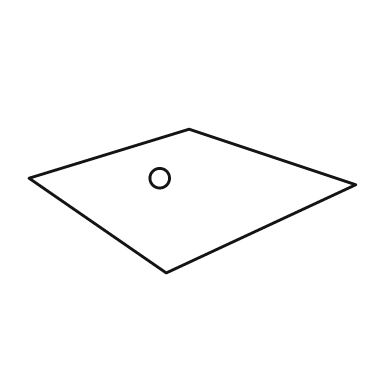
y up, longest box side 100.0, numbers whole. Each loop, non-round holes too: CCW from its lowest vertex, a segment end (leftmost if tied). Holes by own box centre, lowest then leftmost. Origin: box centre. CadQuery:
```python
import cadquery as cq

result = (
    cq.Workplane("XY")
    .moveTo(-8.0, -22.0)
    .lineTo(50.0, 5.0)
    .lineTo(-1.0, 22.0)
    .lineTo(-50.0, 7.0)
    .close()
    .moveTo(-10.0, 7.0)
    .circle(3.0)
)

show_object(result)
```